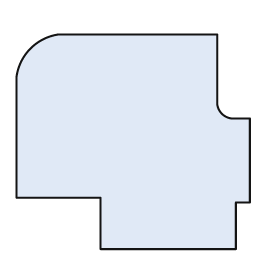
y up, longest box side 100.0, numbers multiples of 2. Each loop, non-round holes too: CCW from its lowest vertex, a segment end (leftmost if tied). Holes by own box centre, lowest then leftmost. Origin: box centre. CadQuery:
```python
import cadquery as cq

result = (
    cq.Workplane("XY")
    .moveTo(-14.0, -46.0)
    .lineTo(44.0, -46.0)
    .lineTo(44.0, -26.0)
    .lineTo(50.0, -26.0)
    .lineTo(50.0, 10.0)
    .lineTo(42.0, 10.0)
    .threePointArc((38.0, 12.0), (36.0, 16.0))
    .lineTo(36.0, 46.0)
    .lineTo(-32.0, 46.0)
    .threePointArc((-44.0, 40.0), (-50.0, 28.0))
    .lineTo(-50.0, -24.0)
    .lineTo(-14.0, -24.0)
    .close()
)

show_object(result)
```